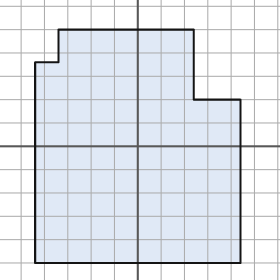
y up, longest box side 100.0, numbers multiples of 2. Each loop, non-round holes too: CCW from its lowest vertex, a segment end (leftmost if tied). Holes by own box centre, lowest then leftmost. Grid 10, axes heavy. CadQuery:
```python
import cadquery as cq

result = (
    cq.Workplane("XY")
    .moveTo(-44.0, -50.0)
    .lineTo(44.0, -50.0)
    .lineTo(44.0, 20.0)
    .lineTo(24.0, 20.0)
    .lineTo(24.0, 50.0)
    .lineTo(-34.0, 50.0)
    .lineTo(-34.0, 36.0)
    .lineTo(-44.0, 36.0)
    .close()
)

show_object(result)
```